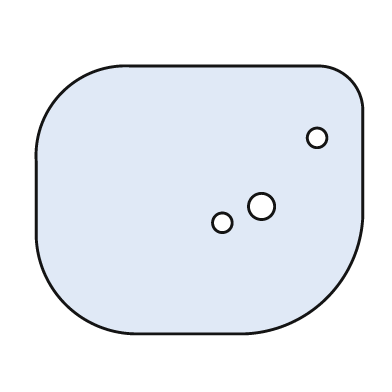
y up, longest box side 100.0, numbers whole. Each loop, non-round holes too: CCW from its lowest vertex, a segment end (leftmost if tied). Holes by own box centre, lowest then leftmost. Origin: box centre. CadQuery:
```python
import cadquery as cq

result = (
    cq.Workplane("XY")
    .moveTo(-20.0, -41.0)
    .lineTo(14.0, -41.0)
    .threePointArc((39.0, -30.0), (50.0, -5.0))
    .lineTo(50.0, 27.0)
    .threePointArc((46.0, 37.0), (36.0, 41.0))
    .lineTo(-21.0, 41.0)
    .threePointArc((-42.0, 33.0), (-50.0, 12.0))
    .lineTo(-50.0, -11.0)
    .threePointArc((-41.0, -32.0), (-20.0, -41.0))
    .close()
    .moveTo(7.0, -7.0)
    .circle(3.0)
    .moveTo(19.0, -2.0)
    .circle(4.0)
    .moveTo(36.0, 19.0)
    .circle(3.0)
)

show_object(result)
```